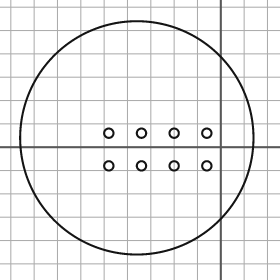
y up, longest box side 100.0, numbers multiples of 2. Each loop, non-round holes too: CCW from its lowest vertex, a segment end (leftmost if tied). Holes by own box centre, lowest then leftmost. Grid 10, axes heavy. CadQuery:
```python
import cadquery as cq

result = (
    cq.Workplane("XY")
    .moveTo(-36.0, 4.0)
    .circle(50.0)
    .moveTo(-48.0, -8.0)
    .circle(2.0)
    .moveTo(-34.0, -8.0)
    .circle(2.0)
    .moveTo(-20.0, -8.0)
    .circle(2.0)
    .moveTo(-6.0, -8.0)
    .circle(2.0)
    .moveTo(-48.0, 6.0)
    .circle(2.0)
    .moveTo(-34.0, 6.0)
    .circle(2.0)
    .moveTo(-20.0, 6.0)
    .circle(2.0)
    .moveTo(-6.0, 6.0)
    .circle(2.0)
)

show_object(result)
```